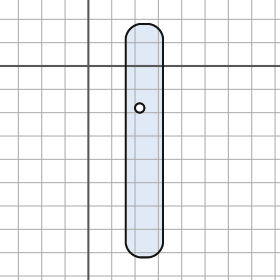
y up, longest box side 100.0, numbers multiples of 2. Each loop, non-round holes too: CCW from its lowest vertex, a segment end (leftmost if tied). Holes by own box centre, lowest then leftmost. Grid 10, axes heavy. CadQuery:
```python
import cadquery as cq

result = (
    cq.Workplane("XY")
    .moveTo(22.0, -82.0)
    .lineTo(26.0, -82.0)
    .threePointArc((30.0, -80.0), (32.0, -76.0))
    .lineTo(32.0, 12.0)
    .threePointArc((30.0, 16.0), (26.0, 18.0))
    .lineTo(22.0, 18.0)
    .threePointArc((18.0, 16.0), (16.0, 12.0))
    .lineTo(16.0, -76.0)
    .threePointArc((18.0, -80.0), (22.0, -82.0))
    .close()
    .moveTo(22.0, -18.0)
    .circle(2.0)
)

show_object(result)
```